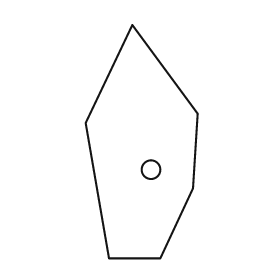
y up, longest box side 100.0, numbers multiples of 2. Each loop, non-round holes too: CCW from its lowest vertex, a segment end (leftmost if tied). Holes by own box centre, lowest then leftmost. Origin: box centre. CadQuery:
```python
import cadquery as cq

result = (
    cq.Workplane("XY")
    .moveTo(-14.0, -50.0)
    .lineTo(8.0, -50.0)
    .lineTo(22.0, -20.0)
    .lineTo(24.0, 12.0)
    .lineTo(-4.0, 50.0)
    .lineTo(-24.0, 8.0)
    .close()
    .moveTo(4.0, -12.0)
    .circle(4.0)
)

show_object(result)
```